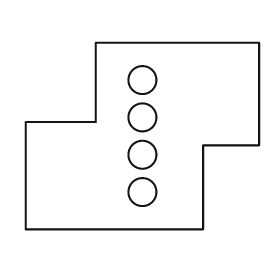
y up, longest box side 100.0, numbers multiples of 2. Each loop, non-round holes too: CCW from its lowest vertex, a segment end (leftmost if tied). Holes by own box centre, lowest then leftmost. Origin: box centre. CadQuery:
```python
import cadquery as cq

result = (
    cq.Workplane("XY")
    .moveTo(-50.0, -40.0)
    .lineTo(26.0, -40.0)
    .lineTo(26.0, -4.0)
    .lineTo(50.0, -4.0)
    .lineTo(50.0, 40.0)
    .lineTo(-20.0, 40.0)
    .lineTo(-20.0, 6.0)
    .lineTo(-50.0, 6.0)
    .close()
    .moveTo(0.0, -24.0)
    .circle(6.0)
    .moveTo(0.0, -8.0)
    .circle(6.0)
    .moveTo(0.0, 8.0)
    .circle(6.0)
    .moveTo(0.0, 24.0)
    .circle(6.0)
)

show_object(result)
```